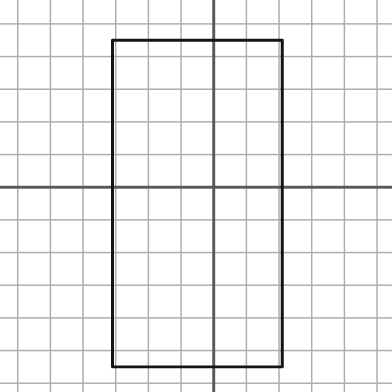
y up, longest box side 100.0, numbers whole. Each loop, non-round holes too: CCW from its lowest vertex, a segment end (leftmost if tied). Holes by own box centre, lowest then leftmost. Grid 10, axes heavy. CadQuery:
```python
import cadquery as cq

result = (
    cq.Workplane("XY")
    .moveTo(-31.0, -55.0)
    .lineTo(21.0, -55.0)
    .lineTo(21.0, 45.0)
    .lineTo(-31.0, 45.0)
    .close()
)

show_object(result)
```